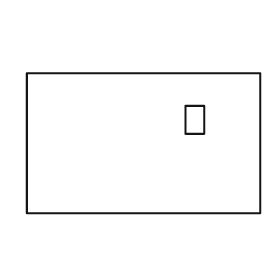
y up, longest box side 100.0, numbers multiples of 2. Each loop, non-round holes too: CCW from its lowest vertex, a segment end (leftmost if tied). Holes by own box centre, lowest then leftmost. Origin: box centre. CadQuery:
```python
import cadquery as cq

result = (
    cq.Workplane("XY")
    .moveTo(-50.0, -30.0)
    .lineTo(50.0, -30.0)
    .lineTo(50.0, 30.0)
    .lineTo(-50.0, 30.0)
    .close()
    .moveTo(18.0, 4.0)
    .lineTo(26.0, 4.0)
    .lineTo(26.0, 16.0)
    .lineTo(18.0, 16.0)
    .close()
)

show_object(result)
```